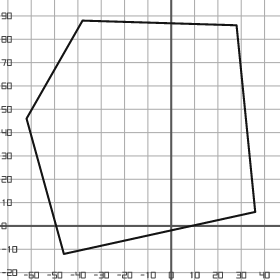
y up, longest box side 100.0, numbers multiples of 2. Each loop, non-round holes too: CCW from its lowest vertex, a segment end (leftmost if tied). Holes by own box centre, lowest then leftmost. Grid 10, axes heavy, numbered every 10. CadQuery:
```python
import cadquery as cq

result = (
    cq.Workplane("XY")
    .moveTo(-46.0, -12.0)
    .lineTo(36.0, 6.0)
    .lineTo(28.0, 86.0)
    .lineTo(-38.0, 88.0)
    .lineTo(-62.0, 46.0)
    .close()
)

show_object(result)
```